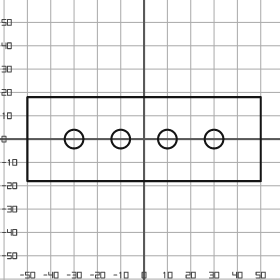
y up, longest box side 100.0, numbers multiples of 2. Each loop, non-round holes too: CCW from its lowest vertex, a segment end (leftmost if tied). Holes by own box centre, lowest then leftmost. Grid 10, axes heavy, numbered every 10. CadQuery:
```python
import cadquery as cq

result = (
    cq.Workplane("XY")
    .moveTo(-50.0, -18.0)
    .lineTo(50.0, -18.0)
    .lineTo(50.0, 18.0)
    .lineTo(-50.0, 18.0)
    .close()
    .moveTo(-30.0, 0.0)
    .circle(4.0)
    .moveTo(-10.0, 0.0)
    .circle(4.0)
    .moveTo(10.0, 0.0)
    .circle(4.0)
    .moveTo(30.0, 0.0)
    .circle(4.0)
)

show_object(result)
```